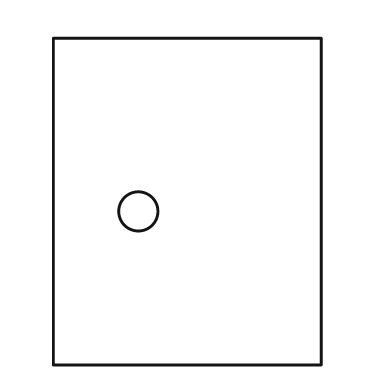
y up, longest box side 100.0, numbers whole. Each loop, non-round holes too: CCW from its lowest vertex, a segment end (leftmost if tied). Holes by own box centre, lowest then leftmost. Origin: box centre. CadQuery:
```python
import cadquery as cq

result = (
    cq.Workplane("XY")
    .moveTo(-41.0, -50.0)
    .lineTo(41.0, -50.0)
    .lineTo(41.0, 50.0)
    .lineTo(-41.0, 50.0)
    .close()
    .moveTo(-15.0, -3.0)
    .circle(6.0)
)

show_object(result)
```